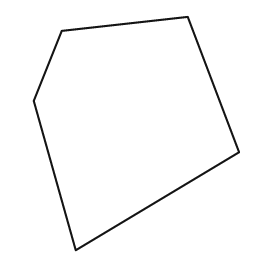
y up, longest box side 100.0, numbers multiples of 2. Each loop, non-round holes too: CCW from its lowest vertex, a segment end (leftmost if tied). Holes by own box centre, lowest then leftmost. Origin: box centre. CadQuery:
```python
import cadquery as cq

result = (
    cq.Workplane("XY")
    .moveTo(-26.0, -50.0)
    .lineTo(44.0, -8.0)
    .lineTo(22.0, 50.0)
    .lineTo(-32.0, 44.0)
    .lineTo(-44.0, 14.0)
    .close()
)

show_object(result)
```